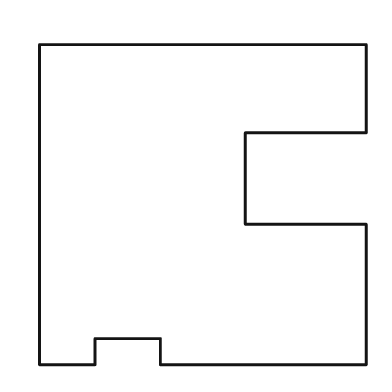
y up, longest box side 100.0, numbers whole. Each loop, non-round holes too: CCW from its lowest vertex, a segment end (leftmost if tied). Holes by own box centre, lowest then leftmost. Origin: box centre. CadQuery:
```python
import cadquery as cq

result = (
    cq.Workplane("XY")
    .moveTo(-50.0, -49.0)
    .lineTo(-33.0, -49.0)
    .lineTo(-33.0, -41.0)
    .lineTo(-13.0, -41.0)
    .lineTo(-13.0, -49.0)
    .lineTo(50.0, -49.0)
    .lineTo(50.0, -6.0)
    .lineTo(13.0, -6.0)
    .lineTo(13.0, 22.0)
    .lineTo(50.0, 22.0)
    .lineTo(50.0, 49.0)
    .lineTo(-50.0, 49.0)
    .close()
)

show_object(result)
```